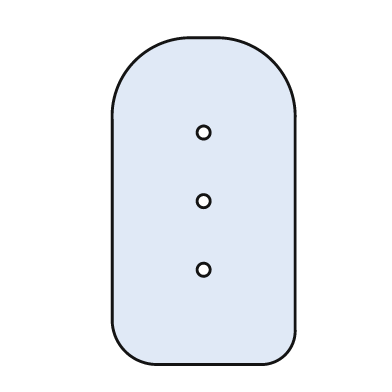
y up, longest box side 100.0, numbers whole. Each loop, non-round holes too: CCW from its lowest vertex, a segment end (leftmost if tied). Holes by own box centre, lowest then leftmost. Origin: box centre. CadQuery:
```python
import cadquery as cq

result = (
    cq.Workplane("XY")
    .moveTo(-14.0, -50.0)
    .lineTo(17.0, -50.0)
    .threePointArc((25.0, -47.0), (28.0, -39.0))
    .lineTo(28.0, 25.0)
    .threePointArc((21.0, 43.0), (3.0, 50.0))
    .lineTo(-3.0, 50.0)
    .threePointArc((-21.0, 43.0), (-28.0, 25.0))
    .lineTo(-28.0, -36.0)
    .threePointArc((-24.0, -46.0), (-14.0, -50.0))
    .close()
    .moveTo(0.0, -21.0)
    .circle(2.0)
    .moveTo(0.0, 0.0)
    .circle(2.0)
    .moveTo(0.0, 21.0)
    .circle(2.0)
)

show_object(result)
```